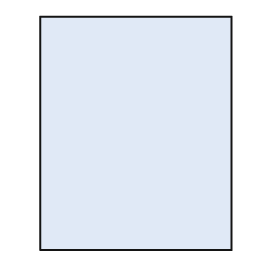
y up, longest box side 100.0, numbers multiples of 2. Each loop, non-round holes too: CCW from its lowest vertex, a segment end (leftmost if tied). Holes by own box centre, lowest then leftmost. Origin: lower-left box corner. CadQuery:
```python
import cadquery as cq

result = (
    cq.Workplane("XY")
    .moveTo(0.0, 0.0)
    .lineTo(82.0, 0.0)
    .lineTo(82.0, 100.0)
    .lineTo(0.0, 100.0)
    .close()
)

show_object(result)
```